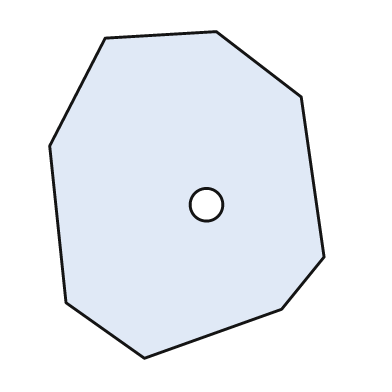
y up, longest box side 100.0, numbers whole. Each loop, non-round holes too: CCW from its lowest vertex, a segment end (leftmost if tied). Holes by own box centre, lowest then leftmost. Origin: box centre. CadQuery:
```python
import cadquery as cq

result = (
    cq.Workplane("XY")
    .moveTo(-13.0, -50.0)
    .lineTo(29.0, -35.0)
    .lineTo(42.0, -19.0)
    .lineTo(35.0, 30.0)
    .lineTo(9.0, 50.0)
    .lineTo(-25.0, 48.0)
    .lineTo(-42.0, 15.0)
    .lineTo(-37.0, -33.0)
    .close()
    .moveTo(6.0, -3.0)
    .circle(5.0)
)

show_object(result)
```